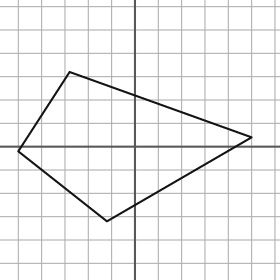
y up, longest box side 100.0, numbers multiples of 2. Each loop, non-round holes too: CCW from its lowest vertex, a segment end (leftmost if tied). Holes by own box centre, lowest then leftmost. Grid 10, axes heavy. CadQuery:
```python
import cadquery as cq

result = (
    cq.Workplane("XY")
    .moveTo(-12.0, -32.0)
    .lineTo(50.0, 4.0)
    .lineTo(-28.0, 32.0)
    .lineTo(-50.0, -2.0)
    .close()
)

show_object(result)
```